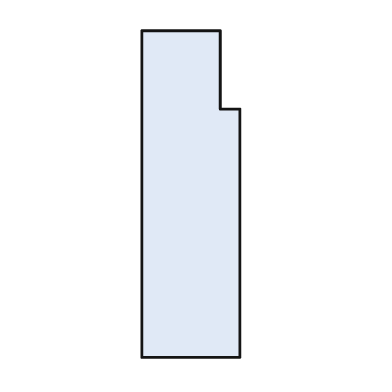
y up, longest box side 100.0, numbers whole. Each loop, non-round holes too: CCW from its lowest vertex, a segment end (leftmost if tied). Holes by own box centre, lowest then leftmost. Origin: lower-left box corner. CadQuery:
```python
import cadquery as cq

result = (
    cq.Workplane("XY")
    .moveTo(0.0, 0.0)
    .lineTo(30.0, 0.0)
    .lineTo(30.0, 76.0)
    .lineTo(24.0, 76.0)
    .lineTo(24.0, 100.0)
    .lineTo(0.0, 100.0)
    .close()
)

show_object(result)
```